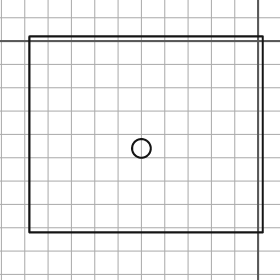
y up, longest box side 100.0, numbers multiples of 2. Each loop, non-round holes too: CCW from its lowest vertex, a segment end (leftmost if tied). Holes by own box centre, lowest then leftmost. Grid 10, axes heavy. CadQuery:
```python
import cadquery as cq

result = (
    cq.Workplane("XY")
    .moveTo(-98.0, -82.0)
    .lineTo(2.0, -82.0)
    .lineTo(2.0, 2.0)
    .lineTo(-98.0, 2.0)
    .close()
    .moveTo(-50.0, -46.0)
    .circle(4.0)
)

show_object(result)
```